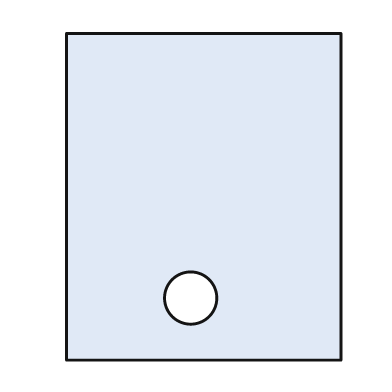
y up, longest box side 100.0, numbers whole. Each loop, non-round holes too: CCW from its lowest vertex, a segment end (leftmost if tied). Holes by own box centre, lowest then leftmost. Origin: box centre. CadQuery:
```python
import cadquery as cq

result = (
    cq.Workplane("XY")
    .moveTo(-42.0, -50.0)
    .lineTo(42.0, -50.0)
    .lineTo(42.0, 50.0)
    .lineTo(-42.0, 50.0)
    .close()
    .moveTo(-4.0, -31.0)
    .circle(8.0)
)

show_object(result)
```